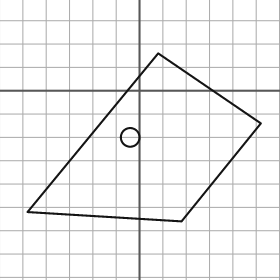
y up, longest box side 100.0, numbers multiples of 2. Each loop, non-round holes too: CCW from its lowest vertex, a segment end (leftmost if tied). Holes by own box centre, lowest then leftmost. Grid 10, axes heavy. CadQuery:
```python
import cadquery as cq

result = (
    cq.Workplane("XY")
    .moveTo(18.0, -56.0)
    .lineTo(52.0, -14.0)
    .lineTo(8.0, 16.0)
    .lineTo(-48.0, -52.0)
    .close()
    .moveTo(-4.0, -20.0)
    .circle(4.0)
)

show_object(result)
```